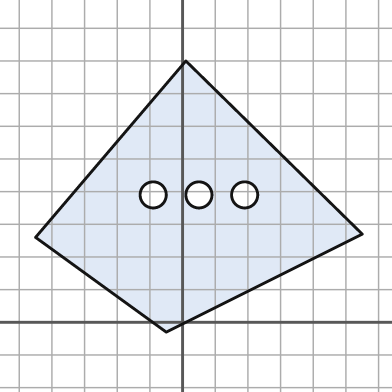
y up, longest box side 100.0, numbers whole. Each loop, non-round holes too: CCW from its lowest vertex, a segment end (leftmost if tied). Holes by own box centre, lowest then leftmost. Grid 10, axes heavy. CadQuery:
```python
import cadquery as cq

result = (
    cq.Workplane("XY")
    .moveTo(-5.0, -3.0)
    .lineTo(55.0, 27.0)
    .lineTo(1.0, 80.0)
    .lineTo(-45.0, 26.0)
    .close()
    .moveTo(-9.0, 39.0)
    .circle(4.0)
    .moveTo(5.0, 39.0)
    .circle(4.0)
    .moveTo(19.0, 39.0)
    .circle(4.0)
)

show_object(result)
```